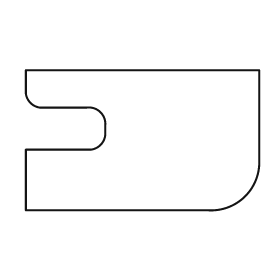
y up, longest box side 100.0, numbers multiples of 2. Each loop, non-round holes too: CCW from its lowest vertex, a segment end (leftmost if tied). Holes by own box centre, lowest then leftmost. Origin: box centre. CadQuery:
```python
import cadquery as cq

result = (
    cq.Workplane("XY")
    .moveTo(-50.0, -30.0)
    .lineTo(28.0, -30.0)
    .threePointArc((44.0, -24.0), (50.0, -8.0))
    .lineTo(50.0, 30.0)
    .lineTo(-50.0, 30.0)
    .lineTo(-50.0, 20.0)
    .threePointArc((-48.0, 16.0), (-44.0, 14.0))
    .lineTo(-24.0, 14.0)
    .threePointArc((-18.0, 12.0), (-16.0, 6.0))
    .lineTo(-16.0, 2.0)
    .threePointArc((-18.0, -2.0), (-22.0, -4.0))
    .lineTo(-50.0, -4.0)
    .close()
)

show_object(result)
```